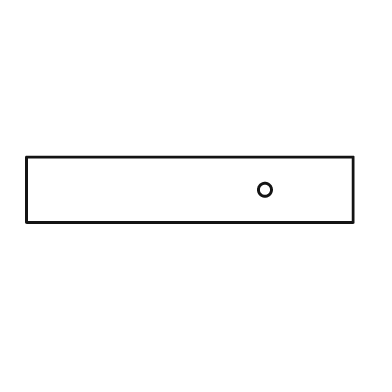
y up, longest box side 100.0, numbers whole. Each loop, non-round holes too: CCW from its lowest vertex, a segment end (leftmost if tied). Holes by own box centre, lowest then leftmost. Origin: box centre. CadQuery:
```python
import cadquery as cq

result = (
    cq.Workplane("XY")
    .moveTo(-50.0, -10.0)
    .lineTo(50.0, -10.0)
    .lineTo(50.0, 10.0)
    .lineTo(-50.0, 10.0)
    .close()
    .moveTo(23.0, 0.0)
    .circle(2.0)
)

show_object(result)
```